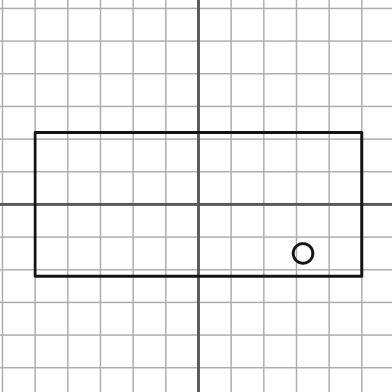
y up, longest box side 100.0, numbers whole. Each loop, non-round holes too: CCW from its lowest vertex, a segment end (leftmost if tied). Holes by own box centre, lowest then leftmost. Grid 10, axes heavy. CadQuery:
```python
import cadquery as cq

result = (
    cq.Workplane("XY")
    .moveTo(-50.0, -22.0)
    .lineTo(50.0, -22.0)
    .lineTo(50.0, 22.0)
    .lineTo(-50.0, 22.0)
    .close()
    .moveTo(32.0, -15.0)
    .circle(3.0)
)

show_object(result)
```